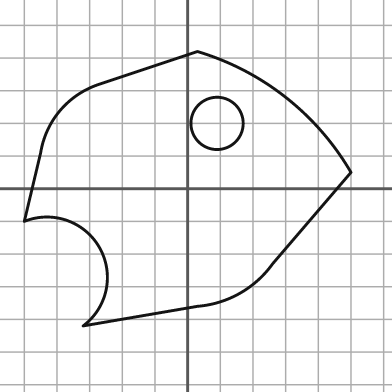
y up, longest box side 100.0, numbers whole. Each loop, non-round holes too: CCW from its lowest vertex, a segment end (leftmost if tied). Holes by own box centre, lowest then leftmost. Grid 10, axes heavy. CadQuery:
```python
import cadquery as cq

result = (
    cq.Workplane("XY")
    .moveTo(-32.0, -42.0)
    .lineTo(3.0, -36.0)
    .threePointArc((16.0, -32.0), (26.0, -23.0))
    .lineTo(50.0, 5.0)
    .threePointArc((30.0, 28.0), (3.0, 42.0))
    .lineTo(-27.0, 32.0)
    .threePointArc((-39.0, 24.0), (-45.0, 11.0))
    .lineTo(-50.0, -10.0)
    .threePointArc((-27.0, -18.0), (-32.0, -42.0))
    .close()
    .moveTo(9.0, 20.0)
    .circle(8.0)
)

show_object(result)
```